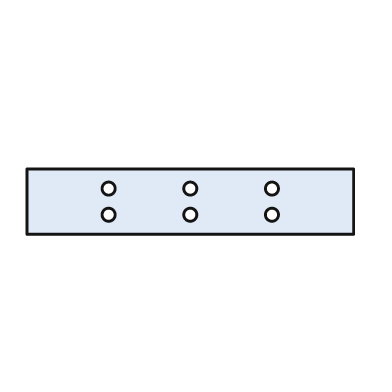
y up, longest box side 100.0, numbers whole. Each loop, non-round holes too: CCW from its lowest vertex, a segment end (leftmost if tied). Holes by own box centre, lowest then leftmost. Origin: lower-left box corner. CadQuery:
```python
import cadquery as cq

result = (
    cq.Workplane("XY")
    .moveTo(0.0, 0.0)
    .lineTo(100.0, 0.0)
    .lineTo(100.0, 20.0)
    .lineTo(0.0, 20.0)
    .close()
    .moveTo(25.0, 6.0)
    .circle(2.0)
    .moveTo(50.0, 6.0)
    .circle(2.0)
    .moveTo(75.0, 6.0)
    .circle(2.0)
    .moveTo(25.0, 14.0)
    .circle(2.0)
    .moveTo(50.0, 14.0)
    .circle(2.0)
    .moveTo(75.0, 14.0)
    .circle(2.0)
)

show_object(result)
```